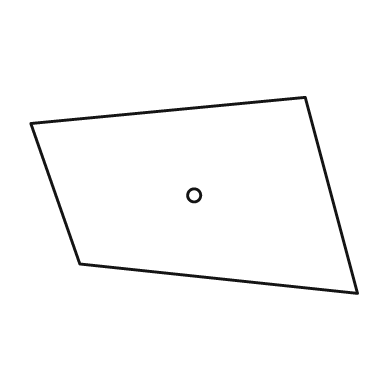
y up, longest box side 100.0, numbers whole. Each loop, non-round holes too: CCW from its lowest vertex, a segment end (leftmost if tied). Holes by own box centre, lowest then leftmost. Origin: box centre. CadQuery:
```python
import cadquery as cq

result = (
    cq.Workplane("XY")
    .moveTo(50.0, -30.0)
    .lineTo(34.0, 30.0)
    .lineTo(-50.0, 22.0)
    .lineTo(-35.0, -21.0)
    .close()
    .moveTo(0.0, 0.0)
    .circle(2.0)
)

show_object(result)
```